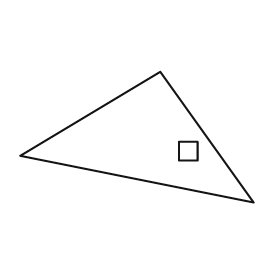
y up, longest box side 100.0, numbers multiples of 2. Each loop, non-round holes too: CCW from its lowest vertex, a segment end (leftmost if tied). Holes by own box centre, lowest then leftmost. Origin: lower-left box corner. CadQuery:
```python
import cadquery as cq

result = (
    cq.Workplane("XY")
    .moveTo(100.0, 0.0)
    .lineTo(60.0, 56.0)
    .lineTo(0.0, 20.0)
    .close()
    .moveTo(68.0, 18.0)
    .lineTo(76.0, 18.0)
    .lineTo(76.0, 26.0)
    .lineTo(68.0, 26.0)
    .close()
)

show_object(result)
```